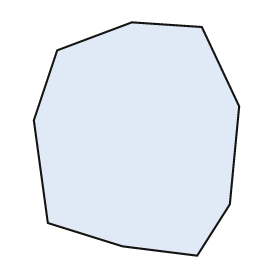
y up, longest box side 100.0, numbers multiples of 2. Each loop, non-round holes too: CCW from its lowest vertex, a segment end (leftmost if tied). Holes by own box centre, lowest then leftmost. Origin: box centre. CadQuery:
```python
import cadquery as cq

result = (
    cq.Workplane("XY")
    .moveTo(26.0, -50.0)
    .lineTo(40.0, -28.0)
    .lineTo(44.0, 14.0)
    .lineTo(28.0, 48.0)
    .lineTo(-2.0, 50.0)
    .lineTo(-34.0, 38.0)
    .lineTo(-44.0, 8.0)
    .lineTo(-38.0, -36.0)
    .lineTo(-6.0, -46.0)
    .close()
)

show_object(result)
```